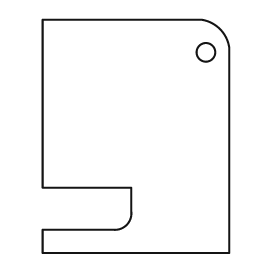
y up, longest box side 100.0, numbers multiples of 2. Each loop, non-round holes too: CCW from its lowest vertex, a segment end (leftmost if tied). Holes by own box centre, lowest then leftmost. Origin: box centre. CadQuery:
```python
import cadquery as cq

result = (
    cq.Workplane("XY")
    .moveTo(-40.0, -50.0)
    .lineTo(40.0, -50.0)
    .lineTo(40.0, 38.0)
    .threePointArc((36.0, 46.0), (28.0, 50.0))
    .lineTo(-40.0, 50.0)
    .lineTo(-40.0, -22.0)
    .lineTo(-2.0, -22.0)
    .lineTo(-2.0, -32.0)
    .threePointArc((-4.0, -38.0), (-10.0, -40.0))
    .lineTo(-40.0, -40.0)
    .close()
    .moveTo(30.0, 36.0)
    .circle(4.0)
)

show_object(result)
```